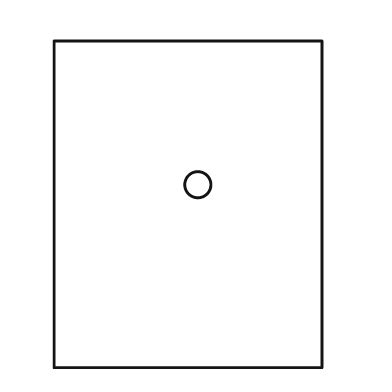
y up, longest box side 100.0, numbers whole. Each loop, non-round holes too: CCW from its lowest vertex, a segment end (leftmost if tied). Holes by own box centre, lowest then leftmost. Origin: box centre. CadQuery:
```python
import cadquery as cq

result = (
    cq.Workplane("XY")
    .moveTo(-41.0, -50.0)
    .lineTo(41.0, -50.0)
    .lineTo(41.0, 50.0)
    .lineTo(-41.0, 50.0)
    .close()
    .moveTo(3.0, 6.0)
    .circle(4.0)
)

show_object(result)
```